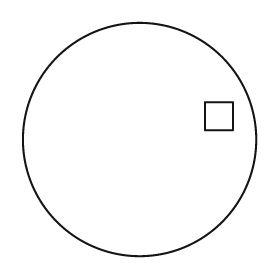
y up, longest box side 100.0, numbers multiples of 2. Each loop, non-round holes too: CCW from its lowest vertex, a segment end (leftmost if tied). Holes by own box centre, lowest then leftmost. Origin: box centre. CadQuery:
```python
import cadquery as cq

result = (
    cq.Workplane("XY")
    .moveTo(0.0, 0.0)
    .circle(50.0)
    .moveTo(28.0, 4.0)
    .lineTo(40.0, 4.0)
    .lineTo(40.0, 16.0)
    .lineTo(28.0, 16.0)
    .close()
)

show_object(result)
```